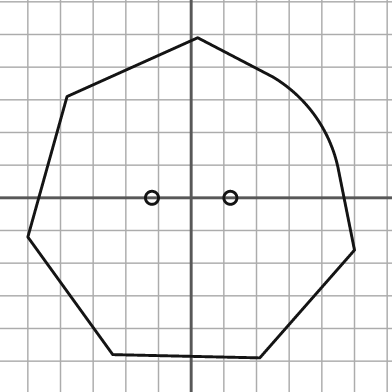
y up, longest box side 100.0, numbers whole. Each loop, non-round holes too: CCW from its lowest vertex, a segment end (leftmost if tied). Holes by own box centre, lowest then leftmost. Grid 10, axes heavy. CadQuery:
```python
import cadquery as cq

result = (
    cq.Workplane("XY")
    .moveTo(21.0, -49.0)
    .lineTo(50.0, -16.0)
    .lineTo(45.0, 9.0)
    .threePointArc((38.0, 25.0), (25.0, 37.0))
    .lineTo(2.0, 49.0)
    .lineTo(-38.0, 31.0)
    .lineTo(-50.0, -12.0)
    .lineTo(-24.0, -48.0)
    .close()
    .moveTo(-12.0, 0.0)
    .circle(2.0)
    .moveTo(12.0, 0.0)
    .circle(2.0)
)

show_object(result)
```